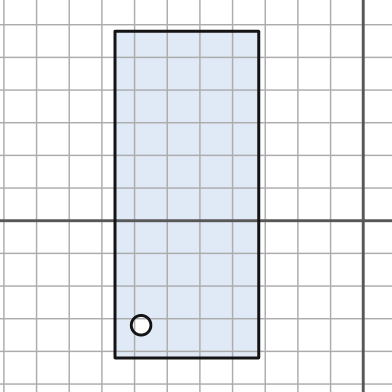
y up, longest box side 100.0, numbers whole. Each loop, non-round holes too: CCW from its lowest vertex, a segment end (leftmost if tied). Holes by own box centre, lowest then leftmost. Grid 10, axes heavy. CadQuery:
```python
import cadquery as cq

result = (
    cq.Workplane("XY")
    .moveTo(-76.0, -42.0)
    .lineTo(-32.0, -42.0)
    .lineTo(-32.0, 58.0)
    .lineTo(-76.0, 58.0)
    .close()
    .moveTo(-68.0, -32.0)
    .circle(3.0)
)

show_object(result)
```